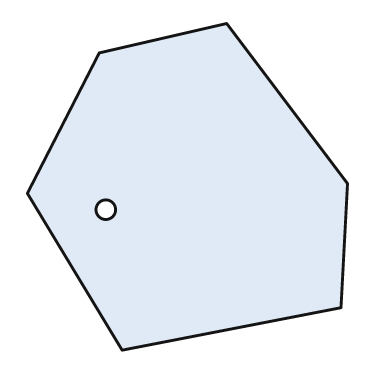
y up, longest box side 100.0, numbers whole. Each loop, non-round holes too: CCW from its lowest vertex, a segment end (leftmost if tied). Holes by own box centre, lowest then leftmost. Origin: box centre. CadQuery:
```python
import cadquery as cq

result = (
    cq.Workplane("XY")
    .moveTo(-20.0, -50.0)
    .lineTo(47.0, -37.0)
    .lineTo(49.0, 1.0)
    .lineTo(12.0, 50.0)
    .lineTo(-27.0, 41.0)
    .lineTo(-49.0, -2.0)
    .close()
    .moveTo(-25.0, -7.0)
    .circle(3.0)
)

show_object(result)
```